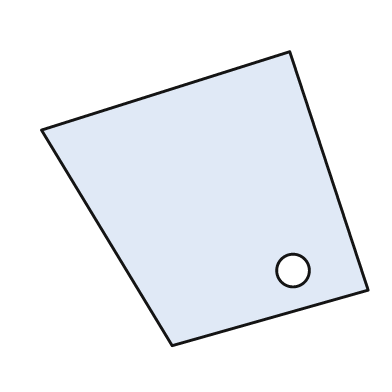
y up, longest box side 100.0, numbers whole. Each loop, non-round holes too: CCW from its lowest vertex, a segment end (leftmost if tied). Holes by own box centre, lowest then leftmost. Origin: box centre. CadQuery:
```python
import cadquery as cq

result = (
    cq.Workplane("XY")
    .moveTo(-10.0, -45.0)
    .lineTo(50.0, -28.0)
    .lineTo(26.0, 45.0)
    .lineTo(-50.0, 21.0)
    .close()
    .moveTo(27.0, -22.0)
    .circle(5.0)
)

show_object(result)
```